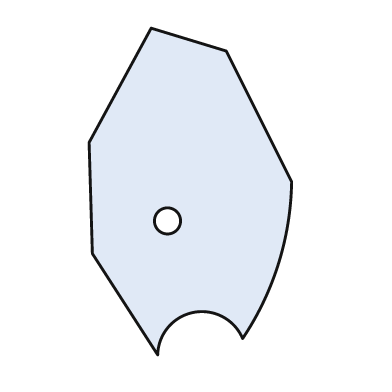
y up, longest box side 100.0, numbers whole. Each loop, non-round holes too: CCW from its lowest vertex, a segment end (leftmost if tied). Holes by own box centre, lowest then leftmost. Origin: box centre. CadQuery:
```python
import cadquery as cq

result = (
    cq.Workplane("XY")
    .moveTo(-10.0, -50.0)
    .threePointArc((1.0, -37.0), (16.0, -45.0))
    .threePointArc((27.0, -22.0), (31.0, 3.0))
    .lineTo(11.0, 43.0)
    .lineTo(-12.0, 50.0)
    .lineTo(-31.0, 15.0)
    .lineTo(-30.0, -19.0)
    .close()
    .moveTo(-7.0, -9.0)
    .circle(4.0)
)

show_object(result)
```